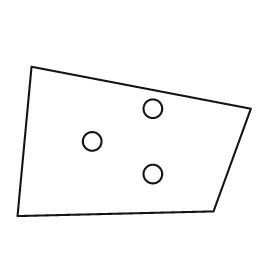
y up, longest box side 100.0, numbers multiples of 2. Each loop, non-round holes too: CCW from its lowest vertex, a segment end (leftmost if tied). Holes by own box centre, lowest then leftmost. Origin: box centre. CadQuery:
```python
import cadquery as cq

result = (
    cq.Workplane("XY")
    .moveTo(-50.0, -32.0)
    .lineTo(34.0, -30.0)
    .lineTo(50.0, 14.0)
    .lineTo(-44.0, 32.0)
    .close()
    .moveTo(8.0, -14.0)
    .circle(4.0)
    .moveTo(-18.0, 0.0)
    .circle(4.0)
    .moveTo(8.0, 14.0)
    .circle(4.0)
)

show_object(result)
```